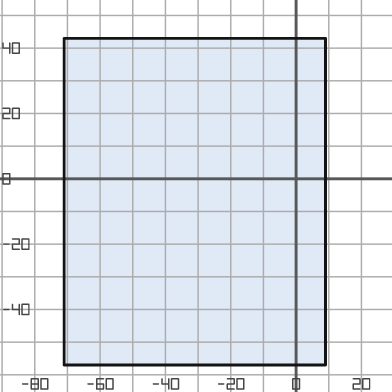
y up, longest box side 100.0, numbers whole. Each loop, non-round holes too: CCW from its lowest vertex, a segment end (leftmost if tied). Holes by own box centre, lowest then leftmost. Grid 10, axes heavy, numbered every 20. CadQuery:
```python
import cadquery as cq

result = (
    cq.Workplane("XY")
    .moveTo(-71.0, -57.0)
    .lineTo(9.0, -57.0)
    .lineTo(9.0, 43.0)
    .lineTo(-71.0, 43.0)
    .close()
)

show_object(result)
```